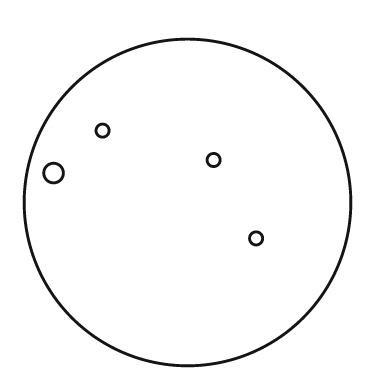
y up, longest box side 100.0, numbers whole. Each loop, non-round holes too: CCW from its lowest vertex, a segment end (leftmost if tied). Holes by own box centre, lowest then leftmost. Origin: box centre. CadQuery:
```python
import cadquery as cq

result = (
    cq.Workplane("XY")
    .moveTo(0.0, 0.0)
    .circle(50.0)
    .moveTo(21.0, -11.0)
    .circle(2.0)
    .moveTo(-41.0, 9.0)
    .circle(3.0)
    .moveTo(8.0, 13.0)
    .circle(2.0)
    .moveTo(-26.0, 22.0)
    .circle(2.0)
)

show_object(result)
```